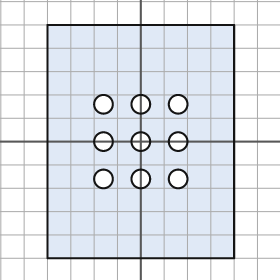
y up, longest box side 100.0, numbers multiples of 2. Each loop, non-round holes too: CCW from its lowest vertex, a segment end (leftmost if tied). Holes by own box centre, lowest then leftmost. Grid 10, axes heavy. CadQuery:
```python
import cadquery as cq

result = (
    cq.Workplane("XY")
    .moveTo(-40.0, -50.0)
    .lineTo(40.0, -50.0)
    .lineTo(40.0, 50.0)
    .lineTo(-40.0, 50.0)
    .close()
    .moveTo(-16.0, -16.0)
    .circle(4.0)
    .moveTo(0.0, -16.0)
    .circle(4.0)
    .moveTo(16.0, -16.0)
    .circle(4.0)
    .moveTo(-16.0, 0.0)
    .circle(4.0)
    .moveTo(0.0, 0.0)
    .circle(4.0)
    .moveTo(16.0, 0.0)
    .circle(4.0)
    .moveTo(-16.0, 16.0)
    .circle(4.0)
    .moveTo(0.0, 16.0)
    .circle(4.0)
    .moveTo(16.0, 16.0)
    .circle(4.0)
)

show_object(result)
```